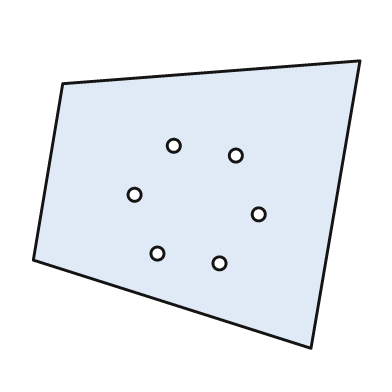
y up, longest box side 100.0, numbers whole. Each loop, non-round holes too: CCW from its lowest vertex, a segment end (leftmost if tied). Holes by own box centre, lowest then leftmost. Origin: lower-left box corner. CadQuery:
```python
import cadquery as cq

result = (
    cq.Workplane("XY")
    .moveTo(85.0, 0.0)
    .lineTo(100.0, 88.0)
    .lineTo(9.0, 81.0)
    .lineTo(0.0, 27.0)
    .close()
    .moveTo(57.0, 26.0)
    .circle(2.0)
    .moveTo(38.0, 29.0)
    .circle(2.0)
    .moveTo(69.0, 41.0)
    .circle(2.0)
    .moveTo(31.0, 47.0)
    .circle(2.0)
    .moveTo(62.0, 59.0)
    .circle(2.0)
    .moveTo(43.0, 62.0)
    .circle(2.0)
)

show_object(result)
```